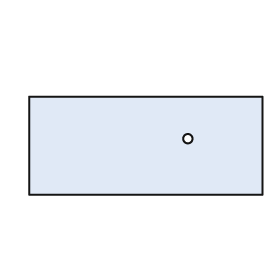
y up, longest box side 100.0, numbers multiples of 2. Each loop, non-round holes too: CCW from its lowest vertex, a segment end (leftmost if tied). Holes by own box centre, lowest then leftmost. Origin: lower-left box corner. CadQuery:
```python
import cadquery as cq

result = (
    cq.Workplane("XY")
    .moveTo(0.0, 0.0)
    .lineTo(100.0, 0.0)
    .lineTo(100.0, 42.0)
    .lineTo(0.0, 42.0)
    .close()
    .moveTo(68.0, 24.0)
    .circle(2.0)
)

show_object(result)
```